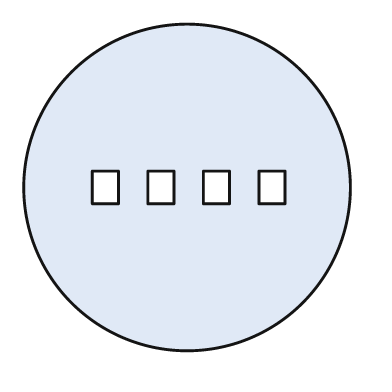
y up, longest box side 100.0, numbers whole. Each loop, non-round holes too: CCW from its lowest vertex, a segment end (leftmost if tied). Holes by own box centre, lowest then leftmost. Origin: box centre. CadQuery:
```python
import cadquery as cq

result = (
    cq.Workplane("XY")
    .moveTo(0.0, 0.0)
    .circle(50.0)
    .moveTo(-29.0, -5.0)
    .lineTo(-21.0, -5.0)
    .lineTo(-21.0, 5.0)
    .lineTo(-29.0, 5.0)
    .close()
    .moveTo(-12.0, -5.0)
    .lineTo(-4.0, -5.0)
    .lineTo(-4.0, 5.0)
    .lineTo(-12.0, 5.0)
    .close()
    .moveTo(5.0, -5.0)
    .lineTo(13.0, -5.0)
    .lineTo(13.0, 5.0)
    .lineTo(5.0, 5.0)
    .close()
    .moveTo(22.0, -5.0)
    .lineTo(30.0, -5.0)
    .lineTo(30.0, 5.0)
    .lineTo(22.0, 5.0)
    .close()
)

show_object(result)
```